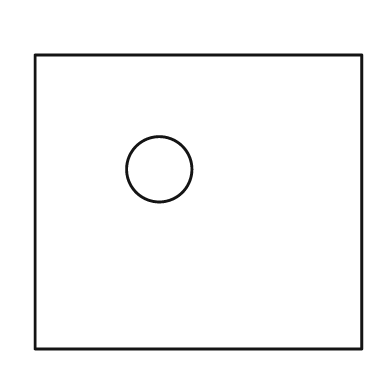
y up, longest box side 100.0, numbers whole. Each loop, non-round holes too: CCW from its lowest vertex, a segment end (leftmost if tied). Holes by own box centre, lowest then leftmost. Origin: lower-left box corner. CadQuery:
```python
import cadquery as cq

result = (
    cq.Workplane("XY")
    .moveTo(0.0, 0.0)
    .lineTo(100.0, 0.0)
    .lineTo(100.0, 90.0)
    .lineTo(0.0, 90.0)
    .close()
    .moveTo(38.0, 55.0)
    .circle(10.0)
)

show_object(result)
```